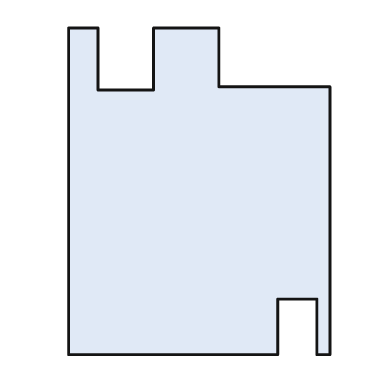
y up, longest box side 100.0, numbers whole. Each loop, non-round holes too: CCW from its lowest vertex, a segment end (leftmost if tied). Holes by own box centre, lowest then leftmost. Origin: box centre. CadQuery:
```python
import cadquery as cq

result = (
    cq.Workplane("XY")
    .moveTo(-40.0, -50.0)
    .lineTo(24.0, -50.0)
    .lineTo(24.0, -33.0)
    .lineTo(36.0, -33.0)
    .lineTo(36.0, -50.0)
    .lineTo(40.0, -50.0)
    .lineTo(40.0, 32.0)
    .lineTo(6.0, 32.0)
    .lineTo(6.0, 50.0)
    .lineTo(-14.0, 50.0)
    .lineTo(-14.0, 31.0)
    .lineTo(-31.0, 31.0)
    .lineTo(-31.0, 50.0)
    .lineTo(-40.0, 50.0)
    .close()
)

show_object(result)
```